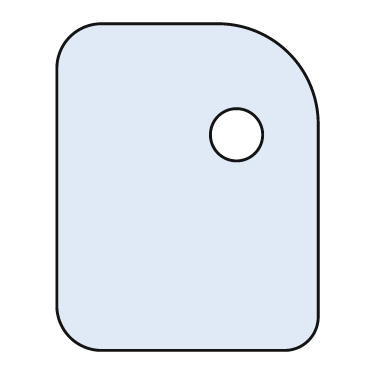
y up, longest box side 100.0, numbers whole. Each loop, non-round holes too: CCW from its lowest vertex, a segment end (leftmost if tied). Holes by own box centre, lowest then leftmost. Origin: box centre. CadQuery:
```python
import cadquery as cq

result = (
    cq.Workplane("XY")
    .moveTo(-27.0, -50.0)
    .lineTo(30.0, -50.0)
    .threePointArc((37.0, -47.0), (40.0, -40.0))
    .lineTo(40.0, 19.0)
    .threePointArc((31.0, 41.0), (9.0, 50.0))
    .lineTo(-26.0, 50.0)
    .threePointArc((-36.0, 46.0), (-40.0, 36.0))
    .lineTo(-40.0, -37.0)
    .threePointArc((-36.0, -46.0), (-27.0, -50.0))
    .close()
    .moveTo(15.0, 16.0)
    .circle(8.0)
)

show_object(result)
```